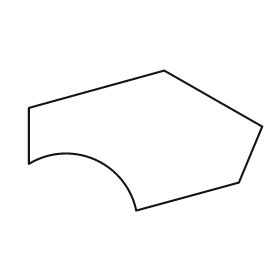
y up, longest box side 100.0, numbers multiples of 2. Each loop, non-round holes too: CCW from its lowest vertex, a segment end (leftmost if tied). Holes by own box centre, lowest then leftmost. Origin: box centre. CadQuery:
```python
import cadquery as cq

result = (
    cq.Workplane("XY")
    .moveTo(-4.0, -30.0)
    .lineTo(40.0, -18.0)
    .lineTo(50.0, 6.0)
    .lineTo(8.0, 30.0)
    .lineTo(-50.0, 14.0)
    .lineTo(-50.0, -10.0)
    .threePointArc((-22.0, -8.0), (-4.0, -30.0))
    .close()
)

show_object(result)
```